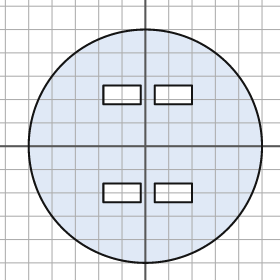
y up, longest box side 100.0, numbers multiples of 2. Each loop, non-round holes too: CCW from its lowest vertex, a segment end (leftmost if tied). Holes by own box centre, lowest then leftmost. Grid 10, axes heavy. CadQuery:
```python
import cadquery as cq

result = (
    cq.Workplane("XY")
    .moveTo(0.0, 0.0)
    .circle(50.0)
    .moveTo(-18.0, -24.0)
    .lineTo(-2.0, -24.0)
    .lineTo(-2.0, -16.0)
    .lineTo(-18.0, -16.0)
    .close()
    .moveTo(4.0, -24.0)
    .lineTo(20.0, -24.0)
    .lineTo(20.0, -16.0)
    .lineTo(4.0, -16.0)
    .close()
    .moveTo(-18.0, 18.0)
    .lineTo(-2.0, 18.0)
    .lineTo(-2.0, 26.0)
    .lineTo(-18.0, 26.0)
    .close()
    .moveTo(4.0, 18.0)
    .lineTo(20.0, 18.0)
    .lineTo(20.0, 26.0)
    .lineTo(4.0, 26.0)
    .close()
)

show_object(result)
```